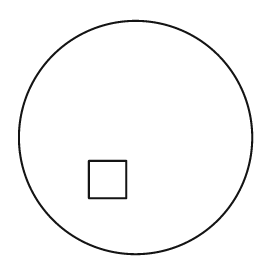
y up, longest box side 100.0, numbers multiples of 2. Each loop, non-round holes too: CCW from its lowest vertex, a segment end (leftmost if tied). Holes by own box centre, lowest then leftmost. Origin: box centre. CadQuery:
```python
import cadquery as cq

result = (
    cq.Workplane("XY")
    .moveTo(0.0, 0.0)
    .circle(50.0)
    .moveTo(-20.0, -26.0)
    .lineTo(-4.0, -26.0)
    .lineTo(-4.0, -10.0)
    .lineTo(-20.0, -10.0)
    .close()
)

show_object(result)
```